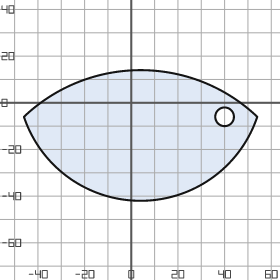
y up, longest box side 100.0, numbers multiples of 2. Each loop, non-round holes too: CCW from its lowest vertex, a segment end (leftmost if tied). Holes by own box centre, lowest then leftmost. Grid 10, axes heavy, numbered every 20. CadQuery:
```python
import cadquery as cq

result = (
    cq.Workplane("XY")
    .moveTo(-46.0, -6.0)
    .threePointArc((4.0, -42.0), (54.0, -6.0))
    .threePointArc((4.0, 14.0), (-46.0, -6.0))
    .close()
    .moveTo(40.0, -6.0)
    .circle(4.0)
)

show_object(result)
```